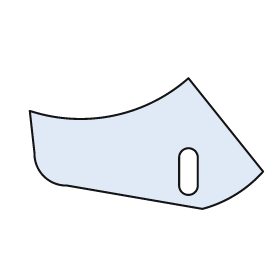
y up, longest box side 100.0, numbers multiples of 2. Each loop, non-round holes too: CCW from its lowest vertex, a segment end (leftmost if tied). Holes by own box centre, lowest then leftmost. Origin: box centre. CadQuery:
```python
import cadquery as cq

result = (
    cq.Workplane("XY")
    .moveTo(24.0, -28.0)
    .threePointArc((38.0, -22.0), (50.0, -12.0))
    .lineTo(18.0, 28.0)
    .threePointArc((-14.0, 12.0), (-50.0, 14.0))
    .lineTo(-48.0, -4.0)
    .threePointArc((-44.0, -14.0), (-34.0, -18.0))
    .close()
    .moveTo(14.0, -18.0)
    .threePointArc((18.0, -22.0), (22.0, -18.0))
    .lineTo(22.0, -6.0)
    .threePointArc((18.0, -2.0), (14.0, -6.0))
    .close()
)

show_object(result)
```